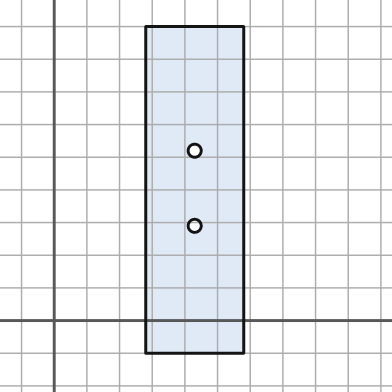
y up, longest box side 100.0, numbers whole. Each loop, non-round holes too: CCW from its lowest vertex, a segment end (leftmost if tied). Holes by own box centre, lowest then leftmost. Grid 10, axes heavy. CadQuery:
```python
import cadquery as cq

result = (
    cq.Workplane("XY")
    .moveTo(28.0, -10.0)
    .lineTo(58.0, -10.0)
    .lineTo(58.0, 90.0)
    .lineTo(28.0, 90.0)
    .close()
    .moveTo(43.0, 29.0)
    .circle(2.0)
    .moveTo(43.0, 52.0)
    .circle(2.0)
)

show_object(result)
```